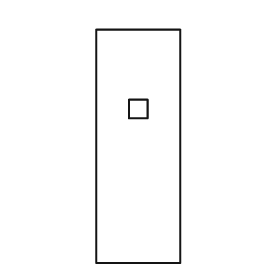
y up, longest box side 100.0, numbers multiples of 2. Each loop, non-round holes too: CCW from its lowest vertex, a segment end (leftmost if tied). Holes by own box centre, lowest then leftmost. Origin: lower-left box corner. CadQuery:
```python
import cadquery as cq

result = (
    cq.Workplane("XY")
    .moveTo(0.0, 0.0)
    .lineTo(36.0, 0.0)
    .lineTo(36.0, 100.0)
    .lineTo(0.0, 100.0)
    .close()
    .moveTo(14.0, 62.0)
    .lineTo(22.0, 62.0)
    .lineTo(22.0, 70.0)
    .lineTo(14.0, 70.0)
    .close()
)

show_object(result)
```